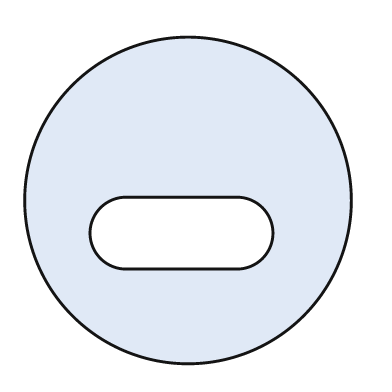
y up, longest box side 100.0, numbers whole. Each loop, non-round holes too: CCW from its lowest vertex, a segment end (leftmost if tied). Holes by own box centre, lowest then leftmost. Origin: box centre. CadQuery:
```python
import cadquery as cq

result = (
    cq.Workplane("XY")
    .moveTo(0.0, 0.0)
    .circle(50.0)
    .moveTo(-19.0, -21.0)
    .lineTo(15.0, -21.0)
    .threePointArc((26.0, -10.0), (15.0, 1.0))
    .lineTo(-19.0, 1.0)
    .threePointArc((-30.0, -10.0), (-19.0, -21.0))
    .close()
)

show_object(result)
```